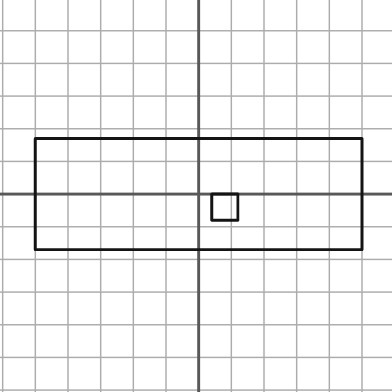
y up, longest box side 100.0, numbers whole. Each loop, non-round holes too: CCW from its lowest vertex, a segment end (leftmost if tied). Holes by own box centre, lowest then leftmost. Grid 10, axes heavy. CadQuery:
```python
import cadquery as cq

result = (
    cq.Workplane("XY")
    .moveTo(-50.0, -17.0)
    .lineTo(50.0, -17.0)
    .lineTo(50.0, 17.0)
    .lineTo(-50.0, 17.0)
    .close()
    .moveTo(4.0, -8.0)
    .lineTo(12.0, -8.0)
    .lineTo(12.0, 0.0)
    .lineTo(4.0, 0.0)
    .close()
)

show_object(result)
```